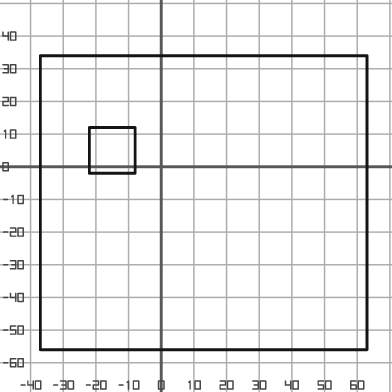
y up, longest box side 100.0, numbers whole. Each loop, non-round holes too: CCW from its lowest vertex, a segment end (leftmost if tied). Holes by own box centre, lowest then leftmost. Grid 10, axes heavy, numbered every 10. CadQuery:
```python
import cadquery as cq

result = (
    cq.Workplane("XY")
    .moveTo(-37.0, -56.0)
    .lineTo(63.0, -56.0)
    .lineTo(63.0, 34.0)
    .lineTo(-37.0, 34.0)
    .close()
    .moveTo(-22.0, -2.0)
    .lineTo(-8.0, -2.0)
    .lineTo(-8.0, 12.0)
    .lineTo(-22.0, 12.0)
    .close()
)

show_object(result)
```